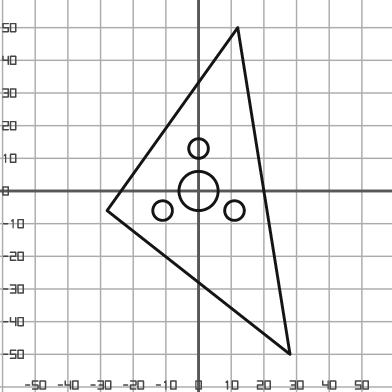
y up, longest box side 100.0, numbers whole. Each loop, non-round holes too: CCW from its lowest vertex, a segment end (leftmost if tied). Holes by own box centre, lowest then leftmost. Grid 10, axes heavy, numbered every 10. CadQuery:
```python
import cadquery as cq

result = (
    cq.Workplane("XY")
    .moveTo(28.0, -50.0)
    .lineTo(12.0, 50.0)
    .lineTo(-28.0, -6.0)
    .close()
    .moveTo(-11.0, -6.0)
    .circle(3.0)
    .moveTo(11.0, -6.0)
    .circle(3.0)
    .moveTo(0.0, 0.0)
    .circle(6.0)
    .moveTo(0.0, 13.0)
    .circle(3.0)
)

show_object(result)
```